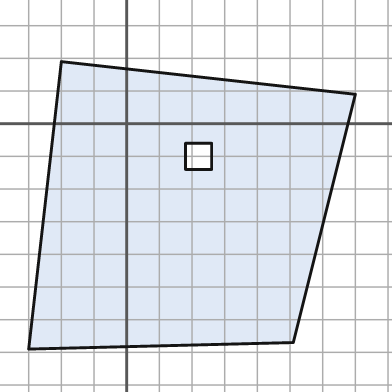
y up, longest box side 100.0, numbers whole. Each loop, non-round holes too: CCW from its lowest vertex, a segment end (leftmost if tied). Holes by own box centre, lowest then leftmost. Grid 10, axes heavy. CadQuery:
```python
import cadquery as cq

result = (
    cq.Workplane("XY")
    .moveTo(-30.0, -69.0)
    .lineTo(51.0, -67.0)
    .lineTo(70.0, 9.0)
    .lineTo(-20.0, 19.0)
    .close()
    .moveTo(18.0, -14.0)
    .lineTo(26.0, -14.0)
    .lineTo(26.0, -6.0)
    .lineTo(18.0, -6.0)
    .close()
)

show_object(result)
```